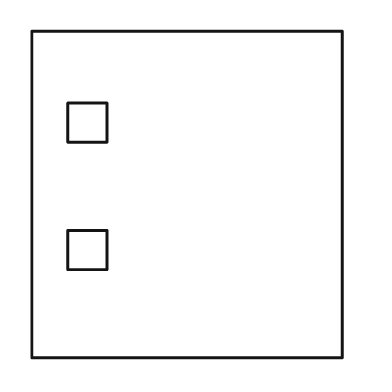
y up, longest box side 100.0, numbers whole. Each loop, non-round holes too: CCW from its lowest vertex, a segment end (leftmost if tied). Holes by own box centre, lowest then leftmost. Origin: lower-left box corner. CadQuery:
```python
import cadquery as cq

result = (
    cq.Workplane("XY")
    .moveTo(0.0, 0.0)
    .lineTo(95.0, 0.0)
    .lineTo(95.0, 100.0)
    .lineTo(0.0, 100.0)
    .close()
    .moveTo(11.0, 27.0)
    .lineTo(23.0, 27.0)
    .lineTo(23.0, 39.0)
    .lineTo(11.0, 39.0)
    .close()
    .moveTo(11.0, 66.0)
    .lineTo(23.0, 66.0)
    .lineTo(23.0, 78.0)
    .lineTo(11.0, 78.0)
    .close()
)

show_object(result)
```